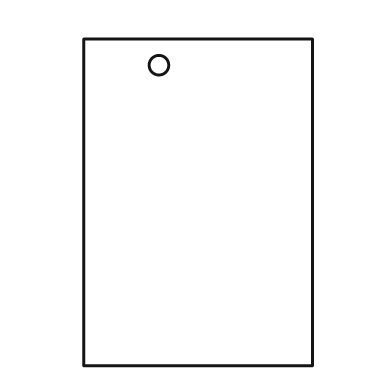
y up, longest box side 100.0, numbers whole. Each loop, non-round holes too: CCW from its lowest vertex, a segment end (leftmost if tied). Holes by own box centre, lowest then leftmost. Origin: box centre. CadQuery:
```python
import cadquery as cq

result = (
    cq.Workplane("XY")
    .moveTo(-35.0, -50.0)
    .lineTo(35.0, -50.0)
    .lineTo(35.0, 50.0)
    .lineTo(-35.0, 50.0)
    .close()
    .moveTo(-12.0, 42.0)
    .circle(3.0)
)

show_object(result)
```